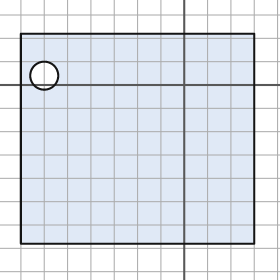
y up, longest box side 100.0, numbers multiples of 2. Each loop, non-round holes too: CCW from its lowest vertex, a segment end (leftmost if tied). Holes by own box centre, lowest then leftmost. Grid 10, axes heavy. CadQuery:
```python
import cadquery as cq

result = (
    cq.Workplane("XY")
    .moveTo(-70.0, -68.0)
    .lineTo(30.0, -68.0)
    .lineTo(30.0, 22.0)
    .lineTo(-70.0, 22.0)
    .close()
    .moveTo(-60.0, 4.0)
    .circle(6.0)
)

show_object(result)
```